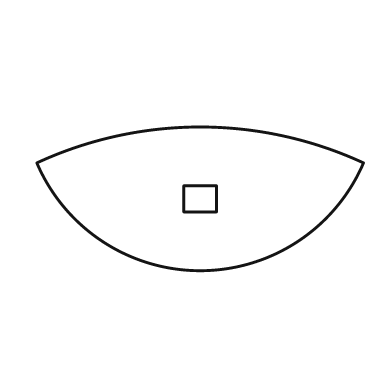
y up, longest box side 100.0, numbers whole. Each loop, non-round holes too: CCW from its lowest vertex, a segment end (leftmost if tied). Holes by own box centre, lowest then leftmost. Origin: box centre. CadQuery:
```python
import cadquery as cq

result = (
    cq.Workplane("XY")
    .moveTo(-50.0, 11.0)
    .threePointArc((0.0, -22.0), (50.0, 11.0))
    .threePointArc((0.0, 22.0), (-50.0, 11.0))
    .close()
    .moveTo(-5.0, -4.0)
    .lineTo(5.0, -4.0)
    .lineTo(5.0, 4.0)
    .lineTo(-5.0, 4.0)
    .close()
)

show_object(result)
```